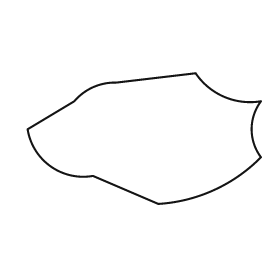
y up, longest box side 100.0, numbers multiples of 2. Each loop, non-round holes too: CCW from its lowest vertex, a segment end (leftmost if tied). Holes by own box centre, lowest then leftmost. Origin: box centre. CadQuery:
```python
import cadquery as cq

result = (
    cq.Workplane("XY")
    .moveTo(6.0, -28.0)
    .threePointArc((30.0, -22.0), (50.0, -8.0))
    .threePointArc((46.0, 4.0), (50.0, 16.0))
    .threePointArc((34.0, 18.0), (22.0, 28.0))
    .lineTo(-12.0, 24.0)
    .threePointArc((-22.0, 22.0), (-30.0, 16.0))
    .lineTo(-50.0, 4.0)
    .threePointArc((-40.0, -12.0), (-22.0, -16.0))
    .close()
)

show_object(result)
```